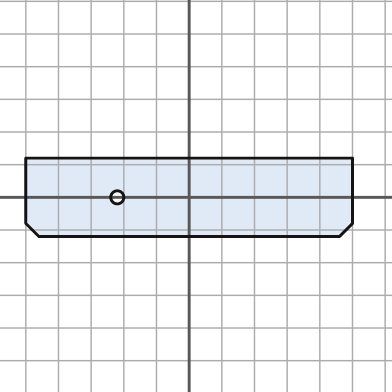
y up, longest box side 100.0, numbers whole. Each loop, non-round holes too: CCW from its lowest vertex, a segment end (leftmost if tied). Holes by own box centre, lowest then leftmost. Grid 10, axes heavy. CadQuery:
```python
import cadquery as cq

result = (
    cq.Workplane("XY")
    .moveTo(-46.0, -12.0)
    .lineTo(46.0, -12.0)
    .lineTo(50.0, -8.0)
    .lineTo(50.0, 12.0)
    .lineTo(-50.0, 12.0)
    .lineTo(-50.0, -8.0)
    .close()
    .moveTo(-22.0, 0.0)
    .circle(2.0)
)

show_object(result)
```